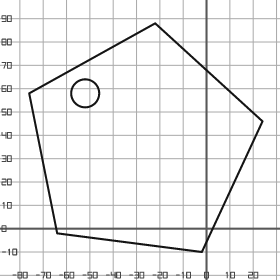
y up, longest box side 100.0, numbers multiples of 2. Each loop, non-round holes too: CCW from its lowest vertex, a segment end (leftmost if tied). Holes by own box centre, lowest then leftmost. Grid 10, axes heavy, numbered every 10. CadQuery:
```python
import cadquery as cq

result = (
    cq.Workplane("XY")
    .moveTo(-2.0, -10.0)
    .lineTo(24.0, 46.0)
    .lineTo(-22.0, 88.0)
    .lineTo(-76.0, 58.0)
    .lineTo(-64.0, -2.0)
    .close()
    .moveTo(-52.0, 58.0)
    .circle(6.0)
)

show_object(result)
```